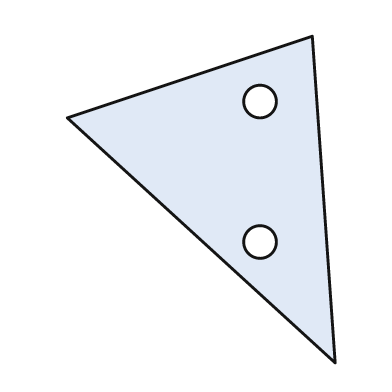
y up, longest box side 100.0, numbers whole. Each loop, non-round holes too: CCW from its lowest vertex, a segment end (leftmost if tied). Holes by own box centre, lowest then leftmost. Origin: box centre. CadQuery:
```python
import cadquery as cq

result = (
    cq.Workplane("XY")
    .moveTo(41.0, -50.0)
    .lineTo(34.0, 50.0)
    .lineTo(-41.0, 25.0)
    .close()
    .moveTo(18.0, -13.0)
    .circle(5.0)
    .moveTo(18.0, 30.0)
    .circle(5.0)
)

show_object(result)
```